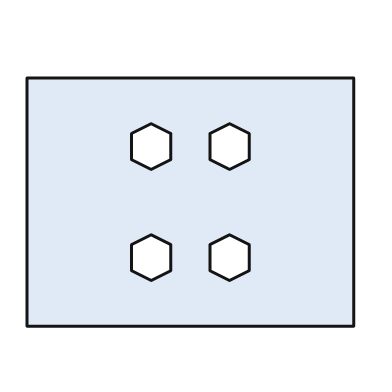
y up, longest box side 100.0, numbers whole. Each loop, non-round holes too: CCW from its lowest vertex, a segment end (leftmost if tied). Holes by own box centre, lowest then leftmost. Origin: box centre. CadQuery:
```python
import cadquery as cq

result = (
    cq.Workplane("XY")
    .moveTo(-50.0, -38.0)
    .lineTo(50.0, -38.0)
    .lineTo(50.0, 38.0)
    .lineTo(-50.0, 38.0)
    .close()
    .moveTo(-12.0, -24.0)
    .lineTo(-6.0, -21.0)
    .lineTo(-6.0, -13.0)
    .lineTo(-12.0, -10.0)
    .lineTo(-18.0, -13.0)
    .lineTo(-18.0, -21.0)
    .close()
    .moveTo(12.0, -24.0)
    .lineTo(18.0, -21.0)
    .lineTo(18.0, -13.0)
    .lineTo(12.0, -10.0)
    .lineTo(6.0, -13.0)
    .lineTo(6.0, -21.0)
    .close()
    .moveTo(-12.0, 10.0)
    .lineTo(-6.0, 13.0)
    .lineTo(-6.0, 21.0)
    .lineTo(-12.0, 24.0)
    .lineTo(-18.0, 21.0)
    .lineTo(-18.0, 13.0)
    .close()
    .moveTo(12.0, 10.0)
    .lineTo(18.0, 13.0)
    .lineTo(18.0, 21.0)
    .lineTo(12.0, 24.0)
    .lineTo(6.0, 21.0)
    .lineTo(6.0, 13.0)
    .close()
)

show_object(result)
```